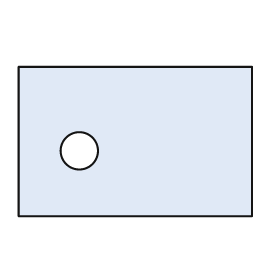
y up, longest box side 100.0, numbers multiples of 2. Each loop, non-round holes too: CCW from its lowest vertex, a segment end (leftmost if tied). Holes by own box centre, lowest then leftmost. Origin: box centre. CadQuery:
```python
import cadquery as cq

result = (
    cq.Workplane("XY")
    .moveTo(-50.0, -32.0)
    .lineTo(50.0, -32.0)
    .lineTo(50.0, 32.0)
    .lineTo(-50.0, 32.0)
    .close()
    .moveTo(-24.0, -4.0)
    .circle(8.0)
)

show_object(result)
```